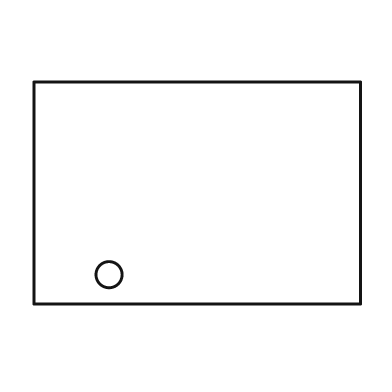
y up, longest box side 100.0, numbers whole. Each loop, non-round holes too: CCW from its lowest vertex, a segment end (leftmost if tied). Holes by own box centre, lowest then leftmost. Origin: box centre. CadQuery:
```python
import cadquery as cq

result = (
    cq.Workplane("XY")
    .moveTo(-50.0, -34.0)
    .lineTo(50.0, -34.0)
    .lineTo(50.0, 34.0)
    .lineTo(-50.0, 34.0)
    .close()
    .moveTo(-27.0, -25.0)
    .circle(4.0)
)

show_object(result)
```